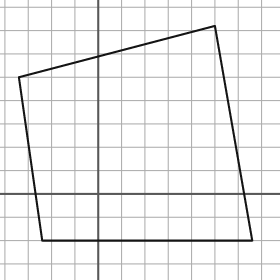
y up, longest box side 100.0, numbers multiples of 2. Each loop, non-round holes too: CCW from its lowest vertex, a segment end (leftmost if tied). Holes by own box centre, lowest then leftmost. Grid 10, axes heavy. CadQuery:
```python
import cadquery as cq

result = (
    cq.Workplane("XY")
    .moveTo(-24.0, -20.0)
    .lineTo(66.0, -20.0)
    .lineTo(50.0, 72.0)
    .lineTo(-34.0, 50.0)
    .close()
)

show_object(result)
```